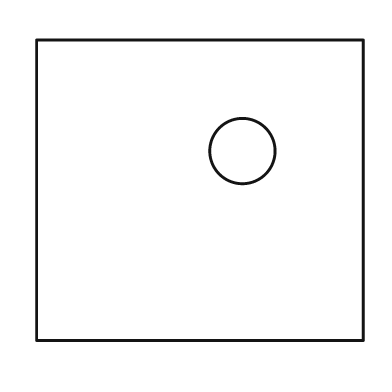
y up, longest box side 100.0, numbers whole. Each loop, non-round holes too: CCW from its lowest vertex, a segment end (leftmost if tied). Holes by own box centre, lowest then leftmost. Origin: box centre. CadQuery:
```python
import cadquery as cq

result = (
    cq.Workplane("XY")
    .moveTo(-50.0, -46.0)
    .lineTo(50.0, -46.0)
    .lineTo(50.0, 46.0)
    .lineTo(-50.0, 46.0)
    .close()
    .moveTo(13.0, 12.0)
    .circle(10.0)
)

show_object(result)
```